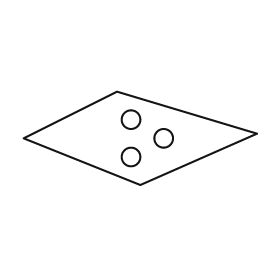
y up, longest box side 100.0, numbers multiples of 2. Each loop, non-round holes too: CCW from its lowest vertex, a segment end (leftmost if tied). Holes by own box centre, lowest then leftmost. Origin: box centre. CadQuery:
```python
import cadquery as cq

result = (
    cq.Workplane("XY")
    .moveTo(0.0, -20.0)
    .lineTo(50.0, 2.0)
    .lineTo(-10.0, 20.0)
    .lineTo(-50.0, 0.0)
    .close()
    .moveTo(-4.0, -8.0)
    .circle(4.0)
    .moveTo(10.0, 0.0)
    .circle(4.0)
    .moveTo(-4.0, 8.0)
    .circle(4.0)
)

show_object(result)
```